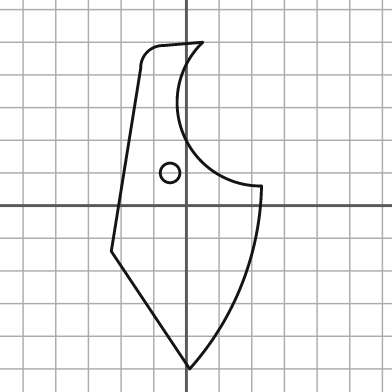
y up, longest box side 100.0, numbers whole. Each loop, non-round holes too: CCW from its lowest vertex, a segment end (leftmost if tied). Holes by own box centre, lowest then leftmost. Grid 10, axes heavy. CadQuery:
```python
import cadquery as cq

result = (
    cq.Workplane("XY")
    .moveTo(1.0, -50.0)
    .threePointArc((17.0, -24.0), (23.0, 6.0))
    .threePointArc((-1.0, 22.0), (5.0, 50.0))
    .lineTo(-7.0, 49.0)
    .threePointArc((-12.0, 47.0), (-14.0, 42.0))
    .lineTo(-23.0, -14.0)
    .close()
    .moveTo(-5.0, 10.0)
    .circle(3.0)
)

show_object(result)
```